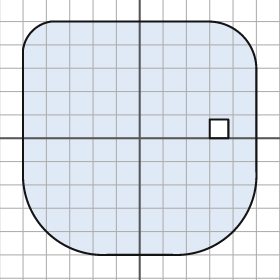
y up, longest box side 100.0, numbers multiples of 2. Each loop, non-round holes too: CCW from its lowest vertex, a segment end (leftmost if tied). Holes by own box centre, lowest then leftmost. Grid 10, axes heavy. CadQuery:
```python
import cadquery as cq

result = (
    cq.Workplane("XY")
    .moveTo(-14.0, -50.0)
    .lineTo(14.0, -50.0)
    .threePointArc((40.0, -40.0), (50.0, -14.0))
    .lineTo(50.0, 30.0)
    .threePointArc((44.0, 44.0), (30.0, 50.0))
    .lineTo(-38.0, 50.0)
    .threePointArc((-46.0, 46.0), (-50.0, 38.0))
    .lineTo(-50.0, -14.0)
    .threePointArc((-40.0, -40.0), (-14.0, -50.0))
    .close()
    .moveTo(30.0, 0.0)
    .lineTo(38.0, 0.0)
    .lineTo(38.0, 8.0)
    .lineTo(30.0, 8.0)
    .close()
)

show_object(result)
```